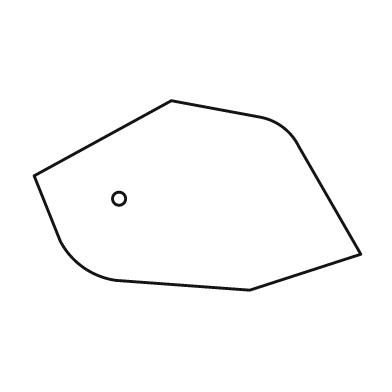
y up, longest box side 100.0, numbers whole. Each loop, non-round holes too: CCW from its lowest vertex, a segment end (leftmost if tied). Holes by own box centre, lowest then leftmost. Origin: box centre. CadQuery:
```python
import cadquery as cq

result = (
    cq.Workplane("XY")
    .moveTo(16.0, -29.0)
    .lineTo(50.0, -18.0)
    .lineTo(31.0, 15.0)
    .threePointArc((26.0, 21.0), (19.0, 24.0))
    .lineTo(-8.0, 29.0)
    .lineTo(-50.0, 6.0)
    .lineTo(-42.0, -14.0)
    .threePointArc((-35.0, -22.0), (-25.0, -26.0))
    .close()
    .moveTo(-24.0, -1.0)
    .circle(2.0)
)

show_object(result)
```